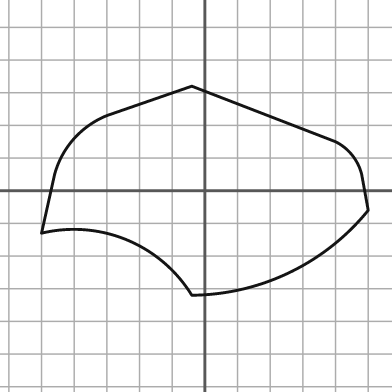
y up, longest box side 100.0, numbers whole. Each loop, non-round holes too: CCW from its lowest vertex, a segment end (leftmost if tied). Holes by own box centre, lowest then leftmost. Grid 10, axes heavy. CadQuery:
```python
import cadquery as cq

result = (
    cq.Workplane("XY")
    .moveTo(-4.0, -32.0)
    .threePointArc((26.0, -25.0), (50.0, -6.0))
    .lineTo(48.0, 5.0)
    .threePointArc((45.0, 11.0), (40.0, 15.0))
    .lineTo(-4.0, 32.0)
    .lineTo(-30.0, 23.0)
    .threePointArc((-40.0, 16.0), (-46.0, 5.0))
    .lineTo(-50.0, -13.0)
    .threePointArc((-24.0, -15.0), (-4.0, -32.0))
    .close()
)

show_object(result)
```